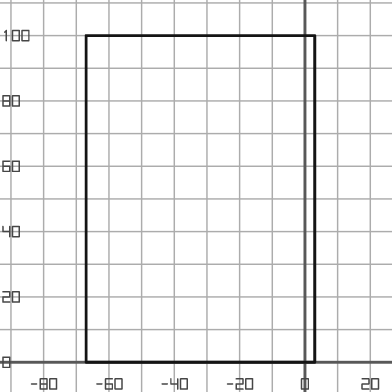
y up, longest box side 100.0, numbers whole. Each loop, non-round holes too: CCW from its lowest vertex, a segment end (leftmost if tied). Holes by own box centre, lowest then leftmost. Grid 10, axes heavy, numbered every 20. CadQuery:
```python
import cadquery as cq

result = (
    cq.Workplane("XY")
    .moveTo(-67.0, 0.0)
    .lineTo(3.0, 0.0)
    .lineTo(3.0, 100.0)
    .lineTo(-67.0, 100.0)
    .close()
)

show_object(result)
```